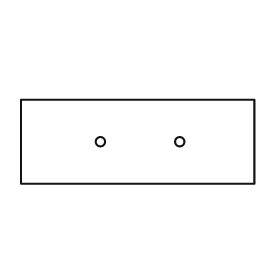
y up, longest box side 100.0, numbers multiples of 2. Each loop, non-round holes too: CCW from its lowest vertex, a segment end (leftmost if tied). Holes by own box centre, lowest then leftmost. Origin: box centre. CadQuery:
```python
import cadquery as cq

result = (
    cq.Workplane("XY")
    .moveTo(-50.0, -18.0)
    .lineTo(50.0, -18.0)
    .lineTo(50.0, 18.0)
    .lineTo(-50.0, 18.0)
    .close()
    .moveTo(-16.0, 0.0)
    .circle(2.0)
    .moveTo(18.0, 0.0)
    .circle(2.0)
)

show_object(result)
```